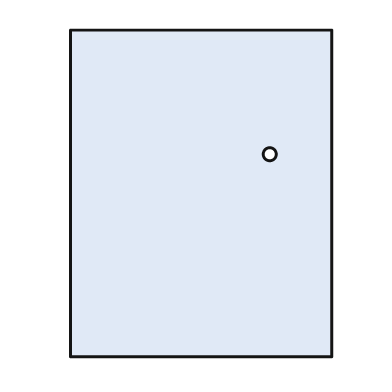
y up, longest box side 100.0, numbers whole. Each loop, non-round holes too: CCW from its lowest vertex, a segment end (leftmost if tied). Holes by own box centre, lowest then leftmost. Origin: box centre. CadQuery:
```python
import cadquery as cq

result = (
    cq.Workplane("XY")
    .moveTo(-40.0, -50.0)
    .lineTo(40.0, -50.0)
    .lineTo(40.0, 50.0)
    .lineTo(-40.0, 50.0)
    .close()
    .moveTo(21.0, 12.0)
    .circle(2.0)
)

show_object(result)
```